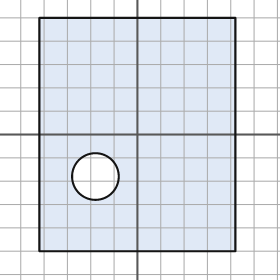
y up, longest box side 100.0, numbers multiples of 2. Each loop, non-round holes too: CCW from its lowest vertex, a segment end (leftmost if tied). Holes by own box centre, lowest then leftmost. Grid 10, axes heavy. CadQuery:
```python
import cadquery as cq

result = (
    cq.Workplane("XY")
    .moveTo(-42.0, -50.0)
    .lineTo(42.0, -50.0)
    .lineTo(42.0, 50.0)
    .lineTo(-42.0, 50.0)
    .close()
    .moveTo(-18.0, -18.0)
    .circle(10.0)
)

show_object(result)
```